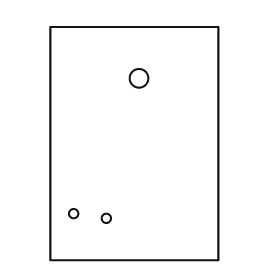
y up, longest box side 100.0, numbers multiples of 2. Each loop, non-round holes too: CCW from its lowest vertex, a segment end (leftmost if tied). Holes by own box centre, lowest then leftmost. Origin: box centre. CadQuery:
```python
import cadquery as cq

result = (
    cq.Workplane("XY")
    .moveTo(-36.0, -50.0)
    .lineTo(36.0, -50.0)
    .lineTo(36.0, 50.0)
    .lineTo(-36.0, 50.0)
    .close()
    .moveTo(-12.0, -32.0)
    .circle(2.0)
    .moveTo(-26.0, -30.0)
    .circle(2.0)
    .moveTo(2.0, 28.0)
    .circle(4.0)
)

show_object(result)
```